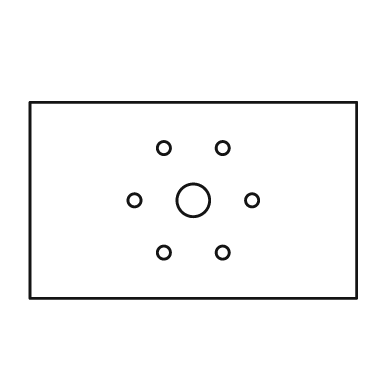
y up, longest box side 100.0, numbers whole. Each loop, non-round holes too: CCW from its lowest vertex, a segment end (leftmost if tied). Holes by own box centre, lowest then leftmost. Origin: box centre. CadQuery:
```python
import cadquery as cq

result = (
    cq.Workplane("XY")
    .moveTo(-50.0, -30.0)
    .lineTo(50.0, -30.0)
    .lineTo(50.0, 30.0)
    .lineTo(-50.0, 30.0)
    .close()
    .moveTo(-9.0, -16.0)
    .circle(2.0)
    .moveTo(9.0, -16.0)
    .circle(2.0)
    .moveTo(-18.0, 0.0)
    .circle(2.0)
    .moveTo(0.0, 0.0)
    .circle(5.0)
    .moveTo(18.0, 0.0)
    .circle(2.0)
    .moveTo(-9.0, 16.0)
    .circle(2.0)
    .moveTo(9.0, 16.0)
    .circle(2.0)
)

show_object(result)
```